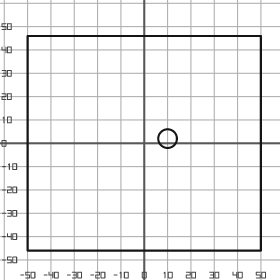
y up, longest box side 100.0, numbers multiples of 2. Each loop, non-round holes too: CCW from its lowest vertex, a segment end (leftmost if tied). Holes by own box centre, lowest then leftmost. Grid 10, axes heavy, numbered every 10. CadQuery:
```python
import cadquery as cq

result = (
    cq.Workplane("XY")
    .moveTo(-50.0, -46.0)
    .lineTo(50.0, -46.0)
    .lineTo(50.0, 46.0)
    .lineTo(-50.0, 46.0)
    .close()
    .moveTo(10.0, 2.0)
    .circle(4.0)
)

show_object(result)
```